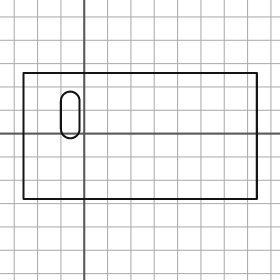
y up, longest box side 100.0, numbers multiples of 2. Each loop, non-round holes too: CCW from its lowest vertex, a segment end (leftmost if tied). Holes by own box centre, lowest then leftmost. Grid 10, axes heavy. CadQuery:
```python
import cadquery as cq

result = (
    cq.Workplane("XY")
    .moveTo(-26.0, -28.0)
    .lineTo(74.0, -28.0)
    .lineTo(74.0, 26.0)
    .lineTo(-26.0, 26.0)
    .close()
    .moveTo(-10.0, 2.0)
    .threePointArc((-6.0, -2.0), (-2.0, 2.0))
    .lineTo(-2.0, 14.0)
    .threePointArc((-6.0, 18.0), (-10.0, 14.0))
    .close()
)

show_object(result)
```